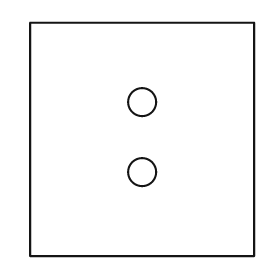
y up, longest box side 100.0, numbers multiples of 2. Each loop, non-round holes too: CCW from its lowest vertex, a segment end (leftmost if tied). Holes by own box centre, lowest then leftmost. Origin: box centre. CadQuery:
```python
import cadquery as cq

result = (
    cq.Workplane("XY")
    .moveTo(-48.0, -50.0)
    .lineTo(48.0, -50.0)
    .lineTo(48.0, 50.0)
    .lineTo(-48.0, 50.0)
    .close()
    .moveTo(0.0, -14.0)
    .circle(6.0)
    .moveTo(0.0, 16.0)
    .circle(6.0)
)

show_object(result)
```